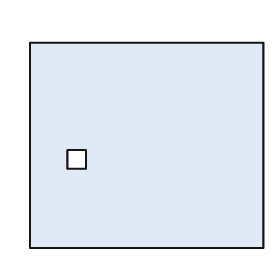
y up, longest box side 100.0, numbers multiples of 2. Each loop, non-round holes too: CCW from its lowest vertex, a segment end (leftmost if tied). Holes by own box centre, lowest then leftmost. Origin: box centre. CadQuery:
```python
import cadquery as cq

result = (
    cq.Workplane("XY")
    .moveTo(-50.0, -44.0)
    .lineTo(50.0, -44.0)
    .lineTo(50.0, 44.0)
    .lineTo(-50.0, 44.0)
    .close()
    .moveTo(-34.0, -10.0)
    .lineTo(-26.0, -10.0)
    .lineTo(-26.0, -2.0)
    .lineTo(-34.0, -2.0)
    .close()
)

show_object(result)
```